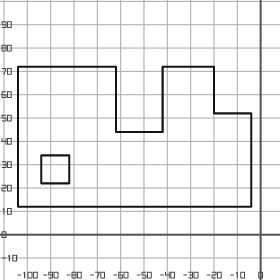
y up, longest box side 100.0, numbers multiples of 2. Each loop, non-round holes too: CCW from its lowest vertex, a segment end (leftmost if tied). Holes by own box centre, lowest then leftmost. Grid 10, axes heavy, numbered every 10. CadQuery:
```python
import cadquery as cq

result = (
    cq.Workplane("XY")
    .moveTo(-104.0, 12.0)
    .lineTo(-4.0, 12.0)
    .lineTo(-4.0, 52.0)
    .lineTo(-20.0, 52.0)
    .lineTo(-20.0, 72.0)
    .lineTo(-42.0, 72.0)
    .lineTo(-42.0, 44.0)
    .lineTo(-62.0, 44.0)
    .lineTo(-62.0, 72.0)
    .lineTo(-104.0, 72.0)
    .close()
    .moveTo(-94.0, 22.0)
    .lineTo(-82.0, 22.0)
    .lineTo(-82.0, 34.0)
    .lineTo(-94.0, 34.0)
    .close()
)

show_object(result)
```